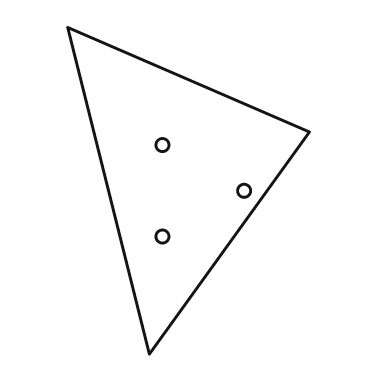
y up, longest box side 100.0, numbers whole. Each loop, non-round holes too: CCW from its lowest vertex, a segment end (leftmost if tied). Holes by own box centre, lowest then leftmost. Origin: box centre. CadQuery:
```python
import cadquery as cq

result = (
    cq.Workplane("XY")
    .moveTo(-12.0, -50.0)
    .lineTo(37.0, 18.0)
    .lineTo(-37.0, 50.0)
    .close()
    .moveTo(-8.0, -14.0)
    .circle(2.0)
    .moveTo(17.0, 0.0)
    .circle(2.0)
    .moveTo(-8.0, 14.0)
    .circle(2.0)
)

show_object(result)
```